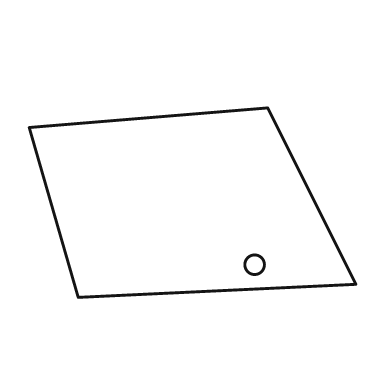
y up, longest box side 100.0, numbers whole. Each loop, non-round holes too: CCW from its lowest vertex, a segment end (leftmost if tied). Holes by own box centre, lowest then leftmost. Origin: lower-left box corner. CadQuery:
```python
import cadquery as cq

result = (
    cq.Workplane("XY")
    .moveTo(15.0, 0.0)
    .lineTo(100.0, 4.0)
    .lineTo(73.0, 58.0)
    .lineTo(0.0, 52.0)
    .close()
    .moveTo(69.0, 10.0)
    .circle(3.0)
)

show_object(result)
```